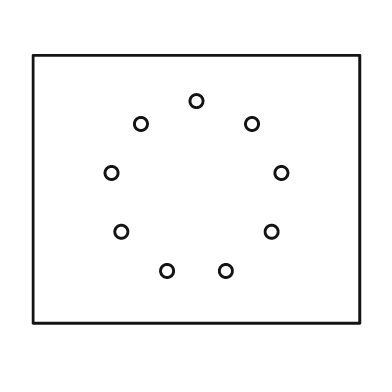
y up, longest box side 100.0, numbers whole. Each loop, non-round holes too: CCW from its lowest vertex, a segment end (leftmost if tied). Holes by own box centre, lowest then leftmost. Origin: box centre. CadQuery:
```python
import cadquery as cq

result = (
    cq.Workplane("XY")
    .moveTo(-50.0, -41.0)
    .lineTo(50.0, -41.0)
    .lineTo(50.0, 41.0)
    .lineTo(-50.0, 41.0)
    .close()
    .moveTo(-9.0, -25.0)
    .circle(2.0)
    .moveTo(9.0, -25.0)
    .circle(2.0)
    .moveTo(-23.0, -13.0)
    .circle(2.0)
    .moveTo(23.0, -13.0)
    .circle(2.0)
    .moveTo(-26.0, 5.0)
    .circle(2.0)
    .moveTo(26.0, 5.0)
    .circle(2.0)
    .moveTo(-17.0, 20.0)
    .circle(2.0)
    .moveTo(17.0, 20.0)
    .circle(2.0)
    .moveTo(0.0, 27.0)
    .circle(2.0)
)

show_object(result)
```